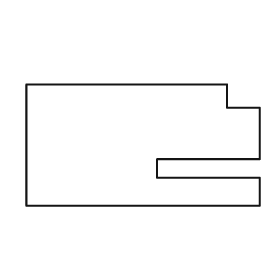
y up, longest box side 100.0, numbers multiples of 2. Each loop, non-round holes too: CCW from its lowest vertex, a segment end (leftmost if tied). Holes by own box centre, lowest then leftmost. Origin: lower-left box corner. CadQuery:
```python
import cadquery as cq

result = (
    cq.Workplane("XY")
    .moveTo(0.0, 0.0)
    .lineTo(100.0, 0.0)
    .lineTo(100.0, 12.0)
    .lineTo(56.0, 12.0)
    .lineTo(56.0, 20.0)
    .lineTo(100.0, 20.0)
    .lineTo(100.0, 42.0)
    .lineTo(86.0, 42.0)
    .lineTo(86.0, 52.0)
    .lineTo(0.0, 52.0)
    .close()
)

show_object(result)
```